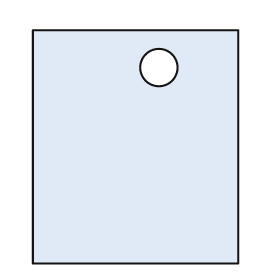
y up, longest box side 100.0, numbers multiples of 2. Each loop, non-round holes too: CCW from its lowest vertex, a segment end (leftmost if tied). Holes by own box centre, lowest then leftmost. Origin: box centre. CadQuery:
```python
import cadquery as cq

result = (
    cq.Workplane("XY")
    .moveTo(-44.0, -50.0)
    .lineTo(44.0, -50.0)
    .lineTo(44.0, 50.0)
    .lineTo(-44.0, 50.0)
    .close()
    .moveTo(10.0, 34.0)
    .circle(8.0)
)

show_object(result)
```